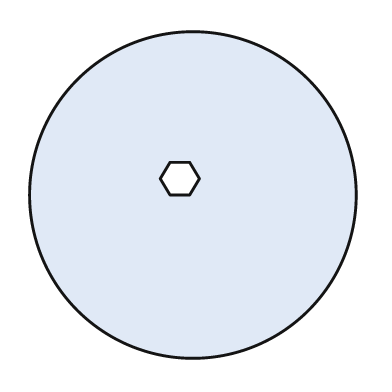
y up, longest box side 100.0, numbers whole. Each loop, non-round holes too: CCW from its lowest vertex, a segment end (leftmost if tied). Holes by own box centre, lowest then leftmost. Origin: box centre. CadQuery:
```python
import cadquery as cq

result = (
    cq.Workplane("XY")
    .moveTo(0.0, 0.0)
    .circle(50.0)
    .moveTo(-7.0, 0.0)
    .lineTo(-1.0, 0.0)
    .lineTo(2.0, 5.0)
    .lineTo(-1.0, 10.0)
    .lineTo(-7.0, 10.0)
    .lineTo(-10.0, 5.0)
    .close()
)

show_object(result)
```